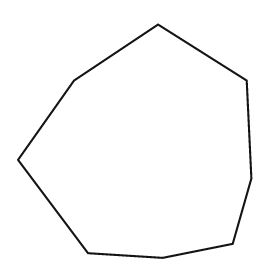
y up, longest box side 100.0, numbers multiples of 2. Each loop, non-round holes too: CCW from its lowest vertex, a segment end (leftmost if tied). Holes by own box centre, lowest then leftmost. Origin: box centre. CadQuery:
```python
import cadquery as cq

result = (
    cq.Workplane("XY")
    .moveTo(12.0, -50.0)
    .lineTo(42.0, -44.0)
    .lineTo(50.0, -16.0)
    .lineTo(48.0, 26.0)
    .lineTo(10.0, 50.0)
    .lineTo(-26.0, 26.0)
    .lineTo(-50.0, -8.0)
    .lineTo(-20.0, -48.0)
    .close()
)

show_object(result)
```